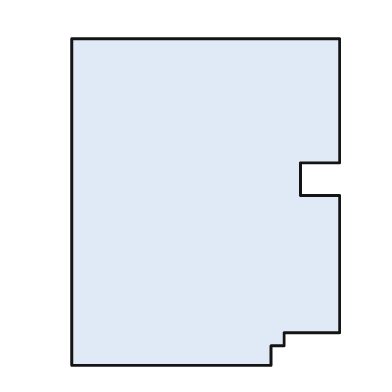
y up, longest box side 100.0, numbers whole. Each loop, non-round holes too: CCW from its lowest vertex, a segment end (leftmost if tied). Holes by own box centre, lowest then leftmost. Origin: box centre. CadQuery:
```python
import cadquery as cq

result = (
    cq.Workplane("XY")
    .moveTo(-41.0, -50.0)
    .lineTo(20.0, -50.0)
    .lineTo(20.0, -44.0)
    .lineTo(24.0, -44.0)
    .lineTo(24.0, -40.0)
    .lineTo(41.0, -40.0)
    .lineTo(41.0, 2.0)
    .lineTo(29.0, 2.0)
    .lineTo(29.0, 12.0)
    .lineTo(41.0, 12.0)
    .lineTo(41.0, 50.0)
    .lineTo(-41.0, 50.0)
    .close()
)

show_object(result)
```